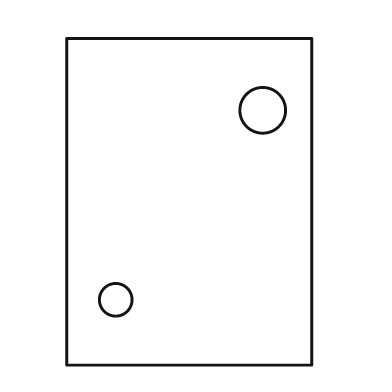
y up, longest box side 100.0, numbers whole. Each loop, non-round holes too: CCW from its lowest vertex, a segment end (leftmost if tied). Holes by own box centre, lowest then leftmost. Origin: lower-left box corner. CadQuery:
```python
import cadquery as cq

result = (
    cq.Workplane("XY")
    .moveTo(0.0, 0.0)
    .lineTo(75.0, 0.0)
    .lineTo(75.0, 100.0)
    .lineTo(0.0, 100.0)
    .close()
    .moveTo(15.0, 20.0)
    .circle(5.0)
    .moveTo(60.0, 78.0)
    .circle(7.0)
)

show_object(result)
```